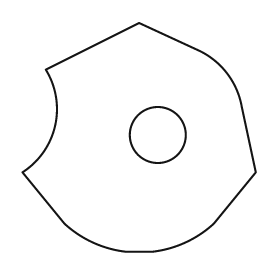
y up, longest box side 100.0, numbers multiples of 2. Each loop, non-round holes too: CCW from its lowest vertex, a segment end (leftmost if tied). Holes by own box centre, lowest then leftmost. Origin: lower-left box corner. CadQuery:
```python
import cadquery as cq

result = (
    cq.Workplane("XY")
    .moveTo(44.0, 0.0)
    .lineTo(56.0, 0.0)
    .threePointArc((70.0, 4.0), (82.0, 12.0))
    .lineTo(100.0, 34.0)
    .lineTo(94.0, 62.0)
    .threePointArc((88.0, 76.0), (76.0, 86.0))
    .lineTo(50.0, 98.0)
    .lineTo(10.0, 78.0)
    .threePointArc((14.0, 54.0), (0.0, 34.0))
    .lineTo(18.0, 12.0)
    .threePointArc((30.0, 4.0), (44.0, 0.0))
    .close()
    .moveTo(58.0, 50.0)
    .circle(12.0)
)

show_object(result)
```